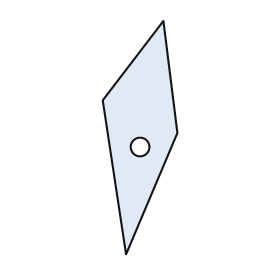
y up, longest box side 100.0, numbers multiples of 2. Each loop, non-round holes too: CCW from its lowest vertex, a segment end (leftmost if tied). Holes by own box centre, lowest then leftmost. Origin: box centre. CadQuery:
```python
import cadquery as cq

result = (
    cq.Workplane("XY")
    .moveTo(-6.0, -50.0)
    .lineTo(16.0, 2.0)
    .lineTo(10.0, 50.0)
    .lineTo(-16.0, 16.0)
    .close()
    .moveTo(0.0, -4.0)
    .circle(4.0)
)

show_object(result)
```